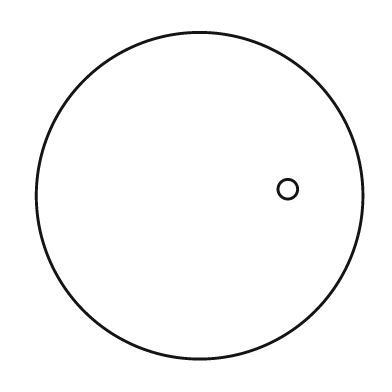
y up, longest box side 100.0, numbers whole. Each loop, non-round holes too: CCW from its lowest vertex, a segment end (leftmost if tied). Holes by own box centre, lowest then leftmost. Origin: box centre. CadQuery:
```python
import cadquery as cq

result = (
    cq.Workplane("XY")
    .moveTo(0.0, 0.0)
    .circle(50.0)
    .moveTo(27.0, 2.0)
    .circle(3.0)
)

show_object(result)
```